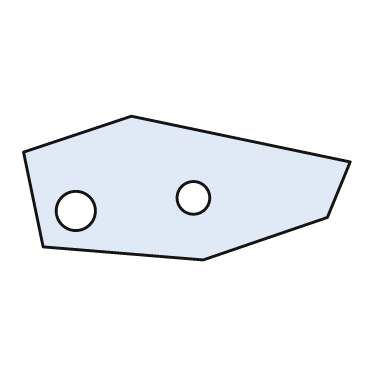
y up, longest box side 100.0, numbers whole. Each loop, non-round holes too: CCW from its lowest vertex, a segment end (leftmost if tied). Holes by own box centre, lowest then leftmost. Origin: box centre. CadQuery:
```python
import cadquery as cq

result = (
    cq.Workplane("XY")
    .moveTo(5.0, -22.0)
    .lineTo(43.0, -9.0)
    .lineTo(50.0, 8.0)
    .lineTo(-17.0, 22.0)
    .lineTo(-50.0, 11.0)
    .lineTo(-44.0, -18.0)
    .close()
    .moveTo(-34.0, -7.0)
    .circle(6.0)
    .moveTo(2.0, -3.0)
    .circle(5.0)
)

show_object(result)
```